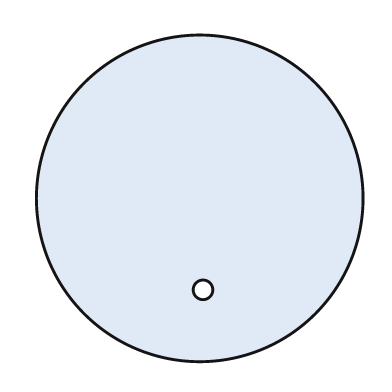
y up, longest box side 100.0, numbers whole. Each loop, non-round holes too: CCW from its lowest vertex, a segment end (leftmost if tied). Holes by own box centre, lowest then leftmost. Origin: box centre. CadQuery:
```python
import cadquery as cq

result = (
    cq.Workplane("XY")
    .moveTo(0.0, 0.0)
    .circle(50.0)
    .moveTo(1.0, -28.0)
    .circle(3.0)
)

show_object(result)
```